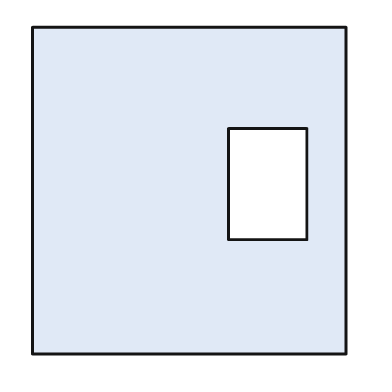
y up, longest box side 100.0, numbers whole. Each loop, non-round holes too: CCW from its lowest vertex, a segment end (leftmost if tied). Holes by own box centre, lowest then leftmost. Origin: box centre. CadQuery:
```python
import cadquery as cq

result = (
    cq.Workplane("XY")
    .moveTo(-48.0, -50.0)
    .lineTo(48.0, -50.0)
    .lineTo(48.0, 50.0)
    .lineTo(-48.0, 50.0)
    .close()
    .moveTo(12.0, -15.0)
    .lineTo(36.0, -15.0)
    .lineTo(36.0, 19.0)
    .lineTo(12.0, 19.0)
    .close()
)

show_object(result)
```